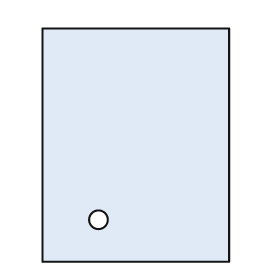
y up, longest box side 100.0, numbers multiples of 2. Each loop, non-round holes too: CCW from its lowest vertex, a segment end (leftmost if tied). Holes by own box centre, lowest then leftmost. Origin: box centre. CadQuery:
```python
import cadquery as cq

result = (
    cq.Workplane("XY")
    .moveTo(-40.0, -50.0)
    .lineTo(40.0, -50.0)
    .lineTo(40.0, 50.0)
    .lineTo(-40.0, 50.0)
    .close()
    .moveTo(-16.0, -32.0)
    .circle(4.0)
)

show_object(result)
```